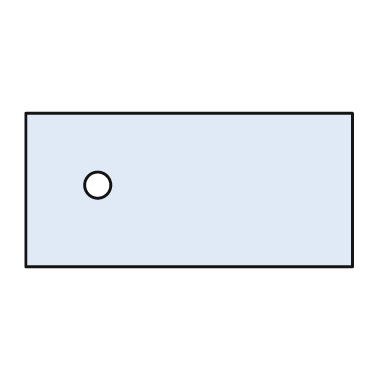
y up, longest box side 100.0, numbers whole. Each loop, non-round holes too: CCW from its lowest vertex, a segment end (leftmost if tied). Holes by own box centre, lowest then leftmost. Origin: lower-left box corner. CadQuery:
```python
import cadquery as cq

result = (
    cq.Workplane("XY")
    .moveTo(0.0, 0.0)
    .lineTo(100.0, 0.0)
    .lineTo(100.0, 47.0)
    .lineTo(0.0, 47.0)
    .close()
    .moveTo(22.0, 25.0)
    .circle(4.0)
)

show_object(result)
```